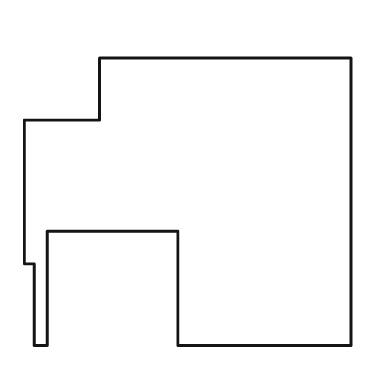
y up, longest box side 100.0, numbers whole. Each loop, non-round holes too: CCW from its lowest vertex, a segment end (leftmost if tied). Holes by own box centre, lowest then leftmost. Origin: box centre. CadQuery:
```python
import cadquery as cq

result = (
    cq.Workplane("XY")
    .moveTo(-47.0, -44.0)
    .lineTo(-43.0, -44.0)
    .lineTo(-43.0, -9.0)
    .lineTo(-3.0, -9.0)
    .lineTo(-3.0, -44.0)
    .lineTo(50.0, -44.0)
    .lineTo(50.0, 44.0)
    .lineTo(-27.0, 44.0)
    .lineTo(-27.0, 25.0)
    .lineTo(-50.0, 25.0)
    .lineTo(-50.0, -19.0)
    .lineTo(-47.0, -19.0)
    .close()
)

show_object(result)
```